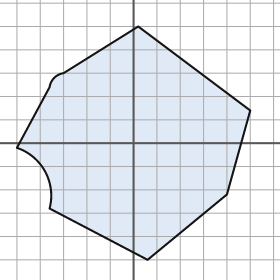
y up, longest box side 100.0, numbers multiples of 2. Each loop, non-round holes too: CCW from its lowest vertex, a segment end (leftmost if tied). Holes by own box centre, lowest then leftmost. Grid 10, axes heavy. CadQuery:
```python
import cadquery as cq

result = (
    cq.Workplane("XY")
    .moveTo(6.0, -50.0)
    .lineTo(40.0, -22.0)
    .lineTo(50.0, 14.0)
    .lineTo(2.0, 50.0)
    .lineTo(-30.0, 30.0)
    .threePointArc((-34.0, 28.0), (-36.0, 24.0))
    .lineTo(-50.0, -2.0)
    .threePointArc((-38.0, -12.0), (-36.0, -28.0))
    .close()
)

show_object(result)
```